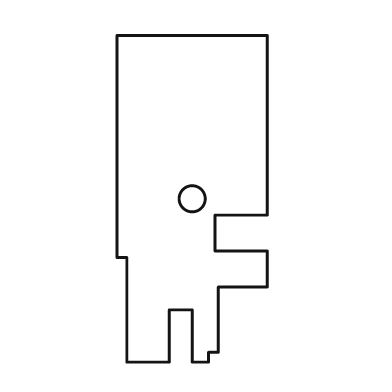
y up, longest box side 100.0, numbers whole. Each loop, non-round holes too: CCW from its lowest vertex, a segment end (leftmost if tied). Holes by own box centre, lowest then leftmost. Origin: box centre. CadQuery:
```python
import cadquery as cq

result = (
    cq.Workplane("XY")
    .moveTo(-20.0, -50.0)
    .lineTo(-7.0, -50.0)
    .lineTo(-7.0, -34.0)
    .lineTo(0.0, -34.0)
    .lineTo(0.0, -50.0)
    .lineTo(5.0, -50.0)
    .lineTo(5.0, -47.0)
    .lineTo(8.0, -47.0)
    .lineTo(8.0, -27.0)
    .lineTo(23.0, -27.0)
    .lineTo(23.0, -16.0)
    .lineTo(7.0, -16.0)
    .lineTo(7.0, -5.0)
    .lineTo(23.0, -5.0)
    .lineTo(23.0, 50.0)
    .lineTo(-23.0, 50.0)
    .lineTo(-23.0, -18.0)
    .lineTo(-20.0, -18.0)
    .close()
    .moveTo(0.0, 0.0)
    .circle(4.0)
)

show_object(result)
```